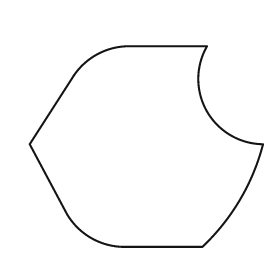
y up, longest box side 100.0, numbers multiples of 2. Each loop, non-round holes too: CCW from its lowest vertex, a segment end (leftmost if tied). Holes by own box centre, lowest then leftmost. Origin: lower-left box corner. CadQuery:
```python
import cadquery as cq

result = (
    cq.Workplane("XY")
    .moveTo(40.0, 0.0)
    .lineTo(74.0, 0.0)
    .threePointArc((90.0, 20.0), (100.0, 44.0))
    .threePointArc((76.0, 58.0), (76.0, 86.0))
    .lineTo(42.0, 86.0)
    .threePointArc((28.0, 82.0), (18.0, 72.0))
    .lineTo(0.0, 44.0)
    .lineTo(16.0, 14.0)
    .threePointArc((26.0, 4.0), (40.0, 0.0))
    .close()
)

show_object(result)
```